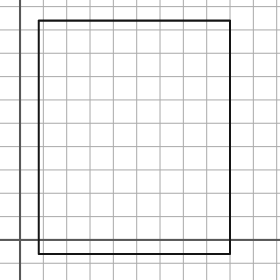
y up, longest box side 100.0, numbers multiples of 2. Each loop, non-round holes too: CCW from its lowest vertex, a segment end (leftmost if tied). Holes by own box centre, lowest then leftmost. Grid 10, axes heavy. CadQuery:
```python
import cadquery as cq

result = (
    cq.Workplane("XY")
    .moveTo(8.0, -6.0)
    .lineTo(90.0, -6.0)
    .lineTo(90.0, 94.0)
    .lineTo(8.0, 94.0)
    .close()
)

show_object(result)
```